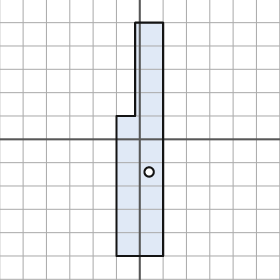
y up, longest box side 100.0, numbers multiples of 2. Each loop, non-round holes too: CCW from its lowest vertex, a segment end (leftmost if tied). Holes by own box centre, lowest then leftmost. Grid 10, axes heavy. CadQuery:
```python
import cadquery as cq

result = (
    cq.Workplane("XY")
    .moveTo(-10.0, -50.0)
    .lineTo(10.0, -50.0)
    .lineTo(10.0, 50.0)
    .lineTo(-2.0, 50.0)
    .lineTo(-2.0, 10.0)
    .lineTo(-10.0, 10.0)
    .close()
    .moveTo(4.0, -14.0)
    .circle(2.0)
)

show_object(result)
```